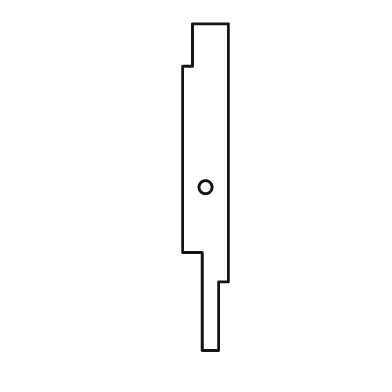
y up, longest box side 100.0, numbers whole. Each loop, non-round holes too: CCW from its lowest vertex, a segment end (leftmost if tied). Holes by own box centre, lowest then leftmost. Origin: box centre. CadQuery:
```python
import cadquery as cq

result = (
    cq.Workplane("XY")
    .moveTo(-1.0, -50.0)
    .lineTo(4.0, -50.0)
    .lineTo(4.0, -29.0)
    .lineTo(7.0, -29.0)
    .lineTo(7.0, 50.0)
    .lineTo(-4.0, 50.0)
    .lineTo(-4.0, 37.0)
    .lineTo(-7.0, 37.0)
    .lineTo(-7.0, -20.0)
    .lineTo(-1.0, -20.0)
    .close()
    .moveTo(0.0, 0.0)
    .circle(2.0)
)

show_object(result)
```